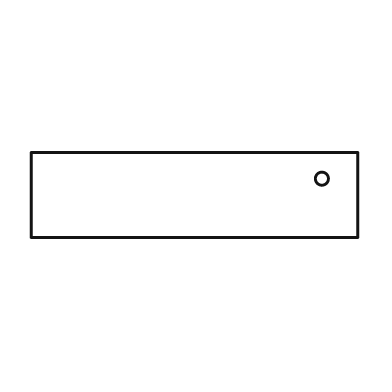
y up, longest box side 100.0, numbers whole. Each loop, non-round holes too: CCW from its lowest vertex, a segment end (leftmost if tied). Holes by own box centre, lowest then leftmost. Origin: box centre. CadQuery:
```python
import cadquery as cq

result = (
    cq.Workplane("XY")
    .moveTo(-50.0, -13.0)
    .lineTo(50.0, -13.0)
    .lineTo(50.0, 13.0)
    .lineTo(-50.0, 13.0)
    .close()
    .moveTo(39.0, 5.0)
    .circle(2.0)
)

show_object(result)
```